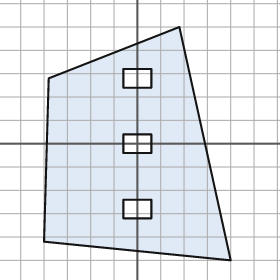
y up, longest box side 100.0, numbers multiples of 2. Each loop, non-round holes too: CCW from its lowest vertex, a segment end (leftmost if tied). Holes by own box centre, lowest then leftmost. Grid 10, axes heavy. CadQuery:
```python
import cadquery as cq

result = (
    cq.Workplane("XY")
    .moveTo(40.0, -50.0)
    .lineTo(18.0, 50.0)
    .lineTo(-38.0, 28.0)
    .lineTo(-40.0, -42.0)
    .close()
    .moveTo(-6.0, -32.0)
    .lineTo(6.0, -32.0)
    .lineTo(6.0, -24.0)
    .lineTo(-6.0, -24.0)
    .close()
    .moveTo(-6.0, -4.0)
    .lineTo(6.0, -4.0)
    .lineTo(6.0, 4.0)
    .lineTo(-6.0, 4.0)
    .close()
    .moveTo(-6.0, 24.0)
    .lineTo(6.0, 24.0)
    .lineTo(6.0, 32.0)
    .lineTo(-6.0, 32.0)
    .close()
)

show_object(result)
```